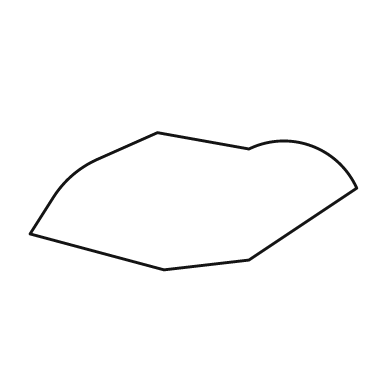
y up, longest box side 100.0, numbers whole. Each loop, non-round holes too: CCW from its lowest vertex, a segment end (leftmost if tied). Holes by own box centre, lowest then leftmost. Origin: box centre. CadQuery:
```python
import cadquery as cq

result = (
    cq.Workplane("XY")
    .moveTo(-9.0, -21.0)
    .lineTo(17.0, -18.0)
    .lineTo(50.0, 4.0)
    .threePointArc((36.0, 17.0), (17.0, 16.0))
    .lineTo(-11.0, 21.0)
    .lineTo(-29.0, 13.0)
    .threePointArc((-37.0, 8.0), (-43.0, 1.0))
    .lineTo(-50.0, -10.0)
    .close()
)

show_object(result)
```